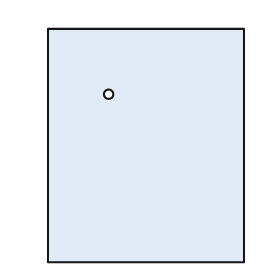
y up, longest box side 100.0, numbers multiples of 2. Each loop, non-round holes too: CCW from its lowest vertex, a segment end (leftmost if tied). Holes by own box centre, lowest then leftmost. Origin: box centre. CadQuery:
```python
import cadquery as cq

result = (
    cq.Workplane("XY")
    .moveTo(-42.0, -50.0)
    .lineTo(42.0, -50.0)
    .lineTo(42.0, 50.0)
    .lineTo(-42.0, 50.0)
    .close()
    .moveTo(-16.0, 22.0)
    .circle(2.0)
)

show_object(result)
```